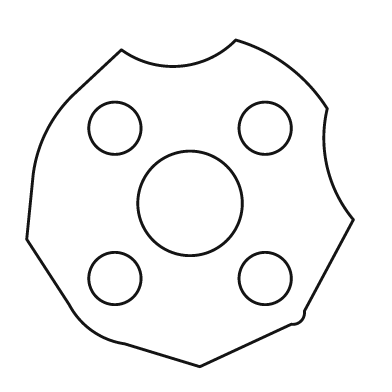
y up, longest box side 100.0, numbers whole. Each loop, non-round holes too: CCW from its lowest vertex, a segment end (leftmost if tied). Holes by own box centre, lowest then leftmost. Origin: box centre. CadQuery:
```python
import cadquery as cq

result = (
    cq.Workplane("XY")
    .moveTo(3.0, -50.0)
    .lineTo(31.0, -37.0)
    .threePointArc((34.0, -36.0), (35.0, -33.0))
    .lineTo(50.0, -5.0)
    .threePointArc((42.0, 11.0), (42.0, 29.0))
    .threePointArc((30.0, 42.0), (14.0, 50.0))
    .threePointArc((-3.0, 42.0), (-21.0, 47.0))
    .lineTo(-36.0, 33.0)
    .threePointArc((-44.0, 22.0), (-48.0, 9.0))
    .lineTo(-50.0, -11.0)
    .lineTo(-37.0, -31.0)
    .threePointArc((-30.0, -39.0), (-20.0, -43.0))
    .close()
    .moveTo(-23.0, -23.0)
    .circle(8.0)
    .moveTo(23.0, -23.0)
    .circle(8.0)
    .moveTo(0.0, 0.0)
    .circle(16.0)
    .moveTo(-23.0, 23.0)
    .circle(8.0)
    .moveTo(23.0, 23.0)
    .circle(8.0)
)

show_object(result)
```